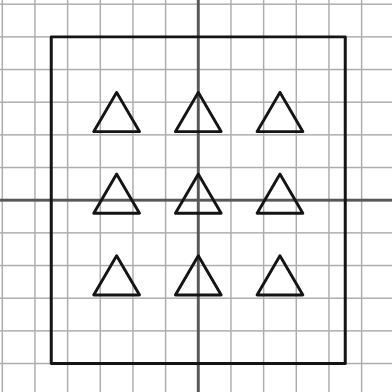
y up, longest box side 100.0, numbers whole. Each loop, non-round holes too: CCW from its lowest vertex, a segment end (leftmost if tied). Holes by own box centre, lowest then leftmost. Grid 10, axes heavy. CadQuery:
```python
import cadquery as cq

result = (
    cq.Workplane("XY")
    .moveTo(-45.0, -50.0)
    .lineTo(45.0, -50.0)
    .lineTo(45.0, 50.0)
    .lineTo(-45.0, 50.0)
    .close()
    .moveTo(-32.0, -29.0)
    .lineTo(-18.0, -29.0)
    .lineTo(-25.0, -17.0)
    .close()
    .moveTo(-7.0, -29.0)
    .lineTo(7.0, -29.0)
    .lineTo(0.0, -17.0)
    .close()
    .moveTo(18.0, -29.0)
    .lineTo(32.0, -29.0)
    .lineTo(25.0, -17.0)
    .close()
    .moveTo(-32.0, -4.0)
    .lineTo(-18.0, -4.0)
    .lineTo(-25.0, 8.0)
    .close()
    .moveTo(-7.0, -4.0)
    .lineTo(7.0, -4.0)
    .lineTo(0.0, 8.0)
    .close()
    .moveTo(18.0, -4.0)
    .lineTo(32.0, -4.0)
    .lineTo(25.0, 8.0)
    .close()
    .moveTo(-32.0, 21.0)
    .lineTo(-18.0, 21.0)
    .lineTo(-25.0, 33.0)
    .close()
    .moveTo(-7.0, 21.0)
    .lineTo(7.0, 21.0)
    .lineTo(0.0, 33.0)
    .close()
    .moveTo(18.0, 21.0)
    .lineTo(32.0, 21.0)
    .lineTo(25.0, 33.0)
    .close()
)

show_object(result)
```